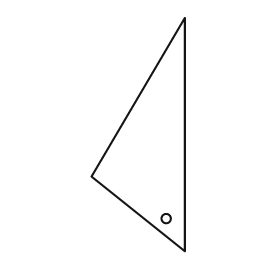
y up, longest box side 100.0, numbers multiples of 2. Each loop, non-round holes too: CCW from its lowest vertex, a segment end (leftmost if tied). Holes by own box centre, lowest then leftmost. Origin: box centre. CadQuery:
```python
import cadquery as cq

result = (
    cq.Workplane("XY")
    .moveTo(20.0, -50.0)
    .lineTo(20.0, 50.0)
    .lineTo(-20.0, -18.0)
    .close()
    .moveTo(12.0, -36.0)
    .circle(2.0)
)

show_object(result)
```